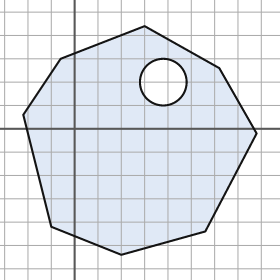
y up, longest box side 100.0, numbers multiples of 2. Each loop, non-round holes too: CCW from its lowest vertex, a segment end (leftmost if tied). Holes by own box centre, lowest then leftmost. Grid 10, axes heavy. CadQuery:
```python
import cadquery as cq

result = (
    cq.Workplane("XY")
    .moveTo(20.0, -54.0)
    .lineTo(56.0, -44.0)
    .lineTo(78.0, -2.0)
    .lineTo(62.0, 26.0)
    .lineTo(30.0, 44.0)
    .lineTo(-6.0, 30.0)
    .lineTo(-22.0, 6.0)
    .lineTo(-10.0, -42.0)
    .close()
    .moveTo(38.0, 20.0)
    .circle(10.0)
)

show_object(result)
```